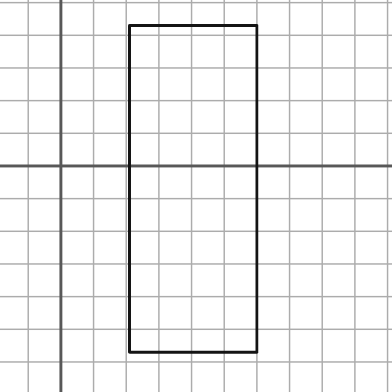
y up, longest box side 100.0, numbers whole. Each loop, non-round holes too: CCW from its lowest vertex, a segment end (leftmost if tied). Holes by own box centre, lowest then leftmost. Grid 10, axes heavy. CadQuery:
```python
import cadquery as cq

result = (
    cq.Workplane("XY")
    .moveTo(21.0, -57.0)
    .lineTo(60.0, -57.0)
    .lineTo(60.0, 43.0)
    .lineTo(21.0, 43.0)
    .close()
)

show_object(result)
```